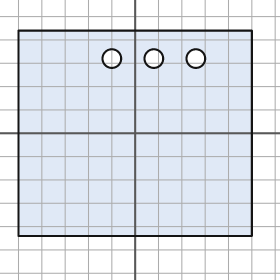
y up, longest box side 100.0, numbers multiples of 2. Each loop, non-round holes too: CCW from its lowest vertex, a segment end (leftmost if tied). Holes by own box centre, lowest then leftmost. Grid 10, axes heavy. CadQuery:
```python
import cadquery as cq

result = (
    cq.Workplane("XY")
    .moveTo(-50.0, -44.0)
    .lineTo(50.0, -44.0)
    .lineTo(50.0, 44.0)
    .lineTo(-50.0, 44.0)
    .close()
    .moveTo(-10.0, 32.0)
    .circle(4.0)
    .moveTo(8.0, 32.0)
    .circle(4.0)
    .moveTo(26.0, 32.0)
    .circle(4.0)
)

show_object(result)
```